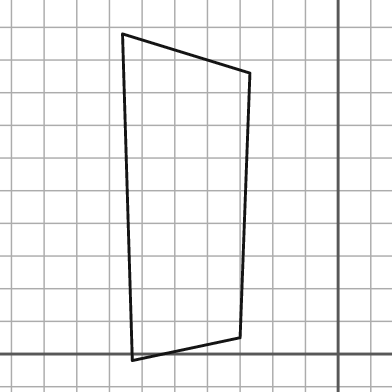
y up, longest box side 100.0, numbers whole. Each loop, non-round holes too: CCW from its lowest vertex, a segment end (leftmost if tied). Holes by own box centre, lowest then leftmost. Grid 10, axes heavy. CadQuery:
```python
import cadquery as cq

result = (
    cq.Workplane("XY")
    .moveTo(-63.0, -2.0)
    .lineTo(-30.0, 5.0)
    .lineTo(-27.0, 86.0)
    .lineTo(-66.0, 98.0)
    .close()
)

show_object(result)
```